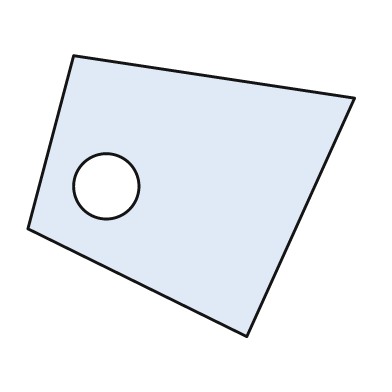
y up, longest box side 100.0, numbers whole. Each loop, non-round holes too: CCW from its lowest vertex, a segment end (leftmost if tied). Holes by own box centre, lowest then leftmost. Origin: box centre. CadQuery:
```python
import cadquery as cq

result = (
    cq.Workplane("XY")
    .moveTo(17.0, -43.0)
    .lineTo(50.0, 30.0)
    .lineTo(-36.0, 43.0)
    .lineTo(-50.0, -10.0)
    .close()
    .moveTo(-26.0, 3.0)
    .circle(10.0)
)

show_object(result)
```